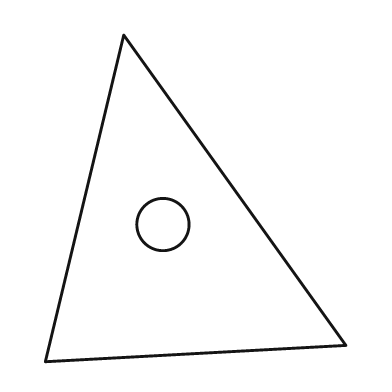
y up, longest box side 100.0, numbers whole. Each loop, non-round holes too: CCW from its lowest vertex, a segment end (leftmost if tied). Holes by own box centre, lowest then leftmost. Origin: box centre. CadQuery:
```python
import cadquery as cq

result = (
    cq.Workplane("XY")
    .moveTo(-46.0, -50.0)
    .lineTo(46.0, -45.0)
    .lineTo(-22.0, 50.0)
    .close()
    .moveTo(-10.0, -8.0)
    .circle(8.0)
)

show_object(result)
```